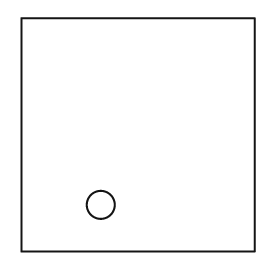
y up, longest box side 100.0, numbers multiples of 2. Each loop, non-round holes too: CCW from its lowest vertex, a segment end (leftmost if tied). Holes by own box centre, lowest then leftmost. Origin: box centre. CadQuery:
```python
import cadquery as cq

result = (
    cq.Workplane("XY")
    .moveTo(-50.0, -50.0)
    .lineTo(50.0, -50.0)
    .lineTo(50.0, 50.0)
    .lineTo(-50.0, 50.0)
    .close()
    .moveTo(-16.0, -30.0)
    .circle(6.0)
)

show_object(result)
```